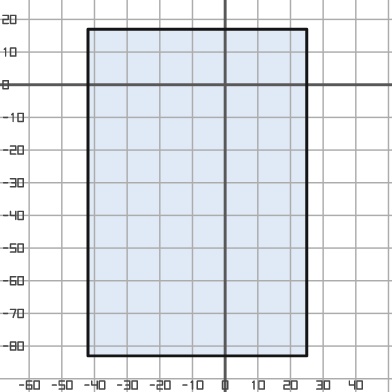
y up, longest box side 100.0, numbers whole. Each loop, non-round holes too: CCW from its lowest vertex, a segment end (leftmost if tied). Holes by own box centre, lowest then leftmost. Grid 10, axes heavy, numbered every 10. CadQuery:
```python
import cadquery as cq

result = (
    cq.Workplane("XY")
    .moveTo(-42.0, -83.0)
    .lineTo(25.0, -83.0)
    .lineTo(25.0, 17.0)
    .lineTo(-42.0, 17.0)
    .close()
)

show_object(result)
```